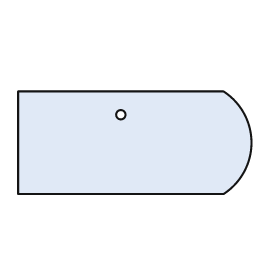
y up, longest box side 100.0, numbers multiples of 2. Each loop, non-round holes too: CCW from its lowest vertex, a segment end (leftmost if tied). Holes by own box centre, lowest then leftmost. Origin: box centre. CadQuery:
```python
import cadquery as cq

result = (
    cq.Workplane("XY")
    .moveTo(-50.0, -22.0)
    .lineTo(38.0, -22.0)
    .threePointArc((50.0, 0.0), (38.0, 22.0))
    .lineTo(-50.0, 22.0)
    .close()
    .moveTo(-6.0, 12.0)
    .circle(2.0)
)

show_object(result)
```